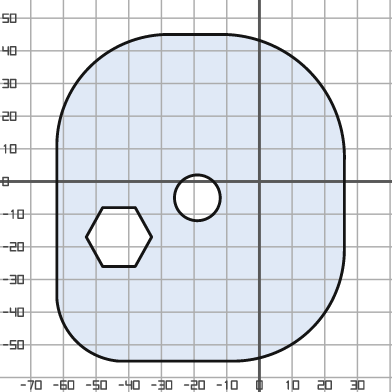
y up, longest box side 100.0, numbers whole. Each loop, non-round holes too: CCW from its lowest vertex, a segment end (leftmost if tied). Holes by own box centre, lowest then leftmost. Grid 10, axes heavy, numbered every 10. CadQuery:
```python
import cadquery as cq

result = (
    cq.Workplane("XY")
    .moveTo(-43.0, -55.0)
    .lineTo(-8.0, -55.0)
    .threePointArc((16.0, -45.0), (26.0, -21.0))
    .lineTo(26.0, 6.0)
    .threePointArc((15.0, 34.0), (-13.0, 45.0))
    .lineTo(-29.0, 45.0)
    .threePointArc((-52.0, 35.0), (-62.0, 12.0))
    .lineTo(-62.0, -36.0)
    .threePointArc((-56.0, -49.0), (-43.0, -55.0))
    .close()
    .moveTo(-48.0, -26.0)
    .lineTo(-38.0, -26.0)
    .lineTo(-33.0, -17.0)
    .lineTo(-38.0, -8.0)
    .lineTo(-48.0, -8.0)
    .lineTo(-53.0, -17.0)
    .close()
    .moveTo(-19.0, -5.0)
    .circle(7.0)
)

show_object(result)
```